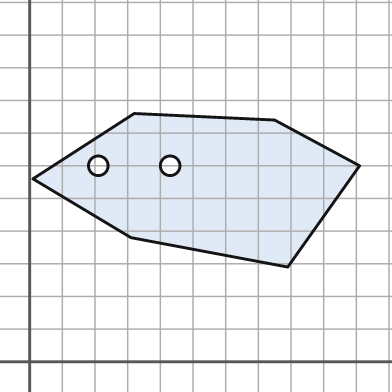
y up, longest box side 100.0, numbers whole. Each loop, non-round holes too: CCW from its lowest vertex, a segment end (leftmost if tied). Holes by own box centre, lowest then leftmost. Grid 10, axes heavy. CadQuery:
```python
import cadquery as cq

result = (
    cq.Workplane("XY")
    .moveTo(79.0, 29.0)
    .lineTo(101.0, 60.0)
    .lineTo(75.0, 74.0)
    .lineTo(32.0, 76.0)
    .lineTo(1.0, 56.0)
    .lineTo(31.0, 38.0)
    .close()
    .moveTo(21.0, 60.0)
    .circle(3.0)
    .moveTo(43.0, 60.0)
    .circle(3.0)
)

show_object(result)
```